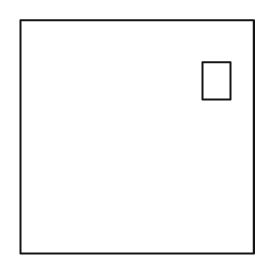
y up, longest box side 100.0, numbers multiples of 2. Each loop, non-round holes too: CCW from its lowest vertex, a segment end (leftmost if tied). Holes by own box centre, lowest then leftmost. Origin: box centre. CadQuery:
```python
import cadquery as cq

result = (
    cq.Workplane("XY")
    .moveTo(-50.0, -50.0)
    .lineTo(50.0, -50.0)
    .lineTo(50.0, 50.0)
    .lineTo(-50.0, 50.0)
    .close()
    .moveTo(28.0, 16.0)
    .lineTo(40.0, 16.0)
    .lineTo(40.0, 32.0)
    .lineTo(28.0, 32.0)
    .close()
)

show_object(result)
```